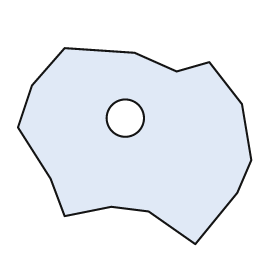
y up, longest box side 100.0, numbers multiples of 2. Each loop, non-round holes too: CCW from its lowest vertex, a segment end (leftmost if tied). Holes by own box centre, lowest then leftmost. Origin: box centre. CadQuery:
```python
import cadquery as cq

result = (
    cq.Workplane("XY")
    .moveTo(26.0, -42.0)
    .lineTo(44.0, -20.0)
    .lineTo(50.0, -6.0)
    .lineTo(46.0, 18.0)
    .lineTo(32.0, 36.0)
    .lineTo(18.0, 32.0)
    .lineTo(0.0, 40.0)
    .lineTo(-30.0, 42.0)
    .lineTo(-44.0, 26.0)
    .lineTo(-50.0, 8.0)
    .lineTo(-36.0, -14.0)
    .lineTo(-30.0, -30.0)
    .lineTo(-10.0, -26.0)
    .lineTo(6.0, -28.0)
    .close()
    .moveTo(-4.0, 12.0)
    .circle(8.0)
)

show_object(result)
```